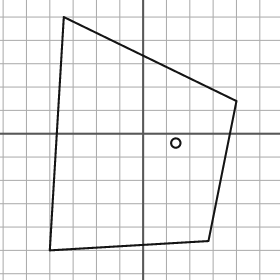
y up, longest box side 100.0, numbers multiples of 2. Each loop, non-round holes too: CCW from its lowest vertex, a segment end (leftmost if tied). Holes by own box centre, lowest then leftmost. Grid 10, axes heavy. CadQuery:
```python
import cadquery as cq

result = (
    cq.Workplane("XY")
    .moveTo(-40.0, -50.0)
    .lineTo(28.0, -46.0)
    .lineTo(40.0, 14.0)
    .lineTo(-34.0, 50.0)
    .close()
    .moveTo(14.0, -4.0)
    .circle(2.0)
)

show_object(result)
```